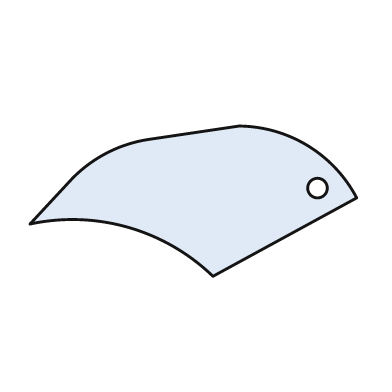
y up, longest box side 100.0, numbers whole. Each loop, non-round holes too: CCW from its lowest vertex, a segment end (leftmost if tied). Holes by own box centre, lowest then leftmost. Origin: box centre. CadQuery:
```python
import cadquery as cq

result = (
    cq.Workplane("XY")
    .moveTo(6.0, -23.0)
    .lineTo(50.0, 1.0)
    .threePointArc((35.0, 17.0), (14.0, 23.0))
    .lineTo(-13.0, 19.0)
    .threePointArc((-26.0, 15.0), (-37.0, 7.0))
    .lineTo(-50.0, -7.0)
    .threePointArc((-20.0, -8.0), (6.0, -23.0))
    .close()
    .moveTo(38.0, 4.0)
    .circle(3.0)
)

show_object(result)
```